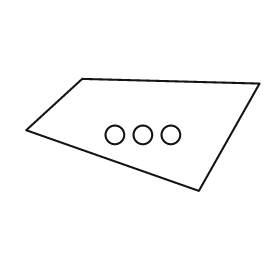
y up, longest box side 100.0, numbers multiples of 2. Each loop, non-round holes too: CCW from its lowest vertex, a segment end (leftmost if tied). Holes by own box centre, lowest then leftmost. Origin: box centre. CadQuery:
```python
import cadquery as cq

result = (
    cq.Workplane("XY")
    .moveTo(24.0, -24.0)
    .lineTo(50.0, 22.0)
    .lineTo(-26.0, 24.0)
    .lineTo(-50.0, 2.0)
    .close()
    .moveTo(-12.0, 0.0)
    .circle(4.0)
    .moveTo(0.0, 0.0)
    .circle(4.0)
    .moveTo(12.0, 0.0)
    .circle(4.0)
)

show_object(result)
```